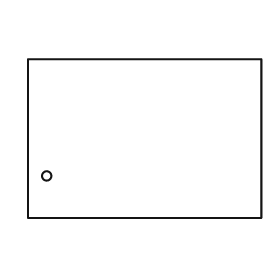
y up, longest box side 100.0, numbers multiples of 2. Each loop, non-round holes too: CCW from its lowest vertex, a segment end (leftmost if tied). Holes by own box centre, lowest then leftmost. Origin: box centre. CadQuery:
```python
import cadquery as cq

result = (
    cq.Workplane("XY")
    .moveTo(-50.0, -34.0)
    .lineTo(50.0, -34.0)
    .lineTo(50.0, 34.0)
    .lineTo(-50.0, 34.0)
    .close()
    .moveTo(-42.0, -16.0)
    .circle(2.0)
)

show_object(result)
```